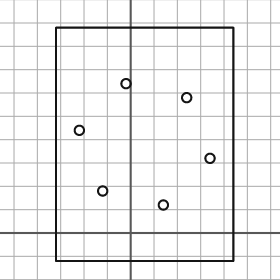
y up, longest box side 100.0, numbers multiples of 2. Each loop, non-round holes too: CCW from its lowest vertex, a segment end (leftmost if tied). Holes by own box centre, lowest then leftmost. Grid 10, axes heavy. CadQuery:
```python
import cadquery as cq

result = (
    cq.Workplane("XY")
    .moveTo(-32.0, -12.0)
    .lineTo(44.0, -12.0)
    .lineTo(44.0, 88.0)
    .lineTo(-32.0, 88.0)
    .close()
    .moveTo(14.0, 12.0)
    .circle(2.0)
    .moveTo(-12.0, 18.0)
    .circle(2.0)
    .moveTo(34.0, 32.0)
    .circle(2.0)
    .moveTo(-22.0, 44.0)
    .circle(2.0)
    .moveTo(24.0, 58.0)
    .circle(2.0)
    .moveTo(-2.0, 64.0)
    .circle(2.0)
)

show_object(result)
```